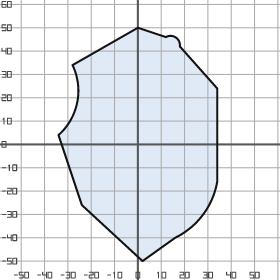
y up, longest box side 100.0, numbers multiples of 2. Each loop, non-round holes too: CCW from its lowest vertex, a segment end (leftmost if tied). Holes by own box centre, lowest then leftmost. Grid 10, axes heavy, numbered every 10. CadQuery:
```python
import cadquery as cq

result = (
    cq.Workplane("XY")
    .moveTo(2.0, -50.0)
    .lineTo(16.0, -40.0)
    .threePointArc((28.0, -30.0), (34.0, -16.0))
    .lineTo(34.0, 24.0)
    .lineTo(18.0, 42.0)
    .threePointArc((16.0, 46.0), (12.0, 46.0))
    .lineTo(0.0, 50.0)
    .lineTo(-28.0, 34.0)
    .threePointArc((-26.0, 18.0), (-34.0, 4.0))
    .lineTo(-24.0, -26.0)
    .close()
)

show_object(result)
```